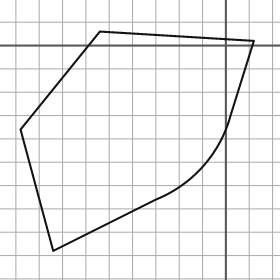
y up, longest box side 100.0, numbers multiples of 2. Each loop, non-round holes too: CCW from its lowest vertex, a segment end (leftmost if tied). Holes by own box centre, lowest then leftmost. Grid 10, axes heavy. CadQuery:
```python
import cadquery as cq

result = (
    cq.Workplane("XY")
    .moveTo(-74.0, -88.0)
    .lineTo(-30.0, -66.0)
    .threePointArc((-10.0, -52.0), (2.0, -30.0))
    .lineTo(12.0, 2.0)
    .lineTo(-54.0, 6.0)
    .lineTo(-88.0, -36.0)
    .close()
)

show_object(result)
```